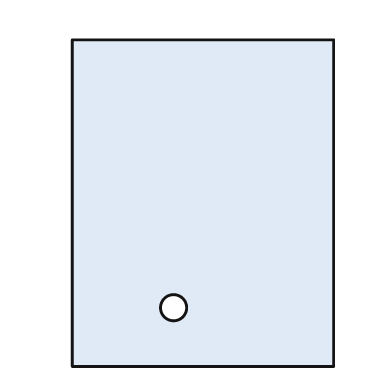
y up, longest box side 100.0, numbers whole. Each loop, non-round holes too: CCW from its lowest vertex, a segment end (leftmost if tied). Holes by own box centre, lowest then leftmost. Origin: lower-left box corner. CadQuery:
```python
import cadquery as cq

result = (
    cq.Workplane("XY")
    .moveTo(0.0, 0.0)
    .lineTo(80.0, 0.0)
    .lineTo(80.0, 100.0)
    .lineTo(0.0, 100.0)
    .close()
    .moveTo(31.0, 18.0)
    .circle(4.0)
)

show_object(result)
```